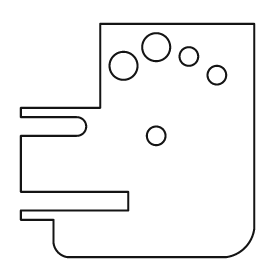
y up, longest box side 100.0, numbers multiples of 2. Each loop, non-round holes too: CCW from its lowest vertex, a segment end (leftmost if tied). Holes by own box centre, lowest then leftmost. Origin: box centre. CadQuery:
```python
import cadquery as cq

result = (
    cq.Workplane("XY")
    .moveTo(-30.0, -50.0)
    .lineTo(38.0, -50.0)
    .threePointArc((46.0, -46.0), (50.0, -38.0))
    .lineTo(50.0, 50.0)
    .lineTo(-16.0, 50.0)
    .lineTo(-16.0, 14.0)
    .lineTo(-50.0, 14.0)
    .lineTo(-50.0, 10.0)
    .lineTo(-26.0, 10.0)
    .threePointArc((-22.0, 6.0), (-26.0, 2.0))
    .lineTo(-50.0, 2.0)
    .lineTo(-50.0, -22.0)
    .lineTo(-4.0, -22.0)
    .lineTo(-4.0, -30.0)
    .lineTo(-50.0, -30.0)
    .lineTo(-50.0, -34.0)
    .lineTo(-36.0, -34.0)
    .lineTo(-36.0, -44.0)
    .threePointArc((-34.0, -48.0), (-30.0, -50.0))
    .close()
    .moveTo(8.0, 2.0)
    .circle(4.0)
    .moveTo(34.0, 28.0)
    .circle(4.0)
    .moveTo(-6.0, 32.0)
    .circle(6.0)
    .moveTo(22.0, 36.0)
    .circle(4.0)
    .moveTo(8.0, 40.0)
    .circle(6.0)
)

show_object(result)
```